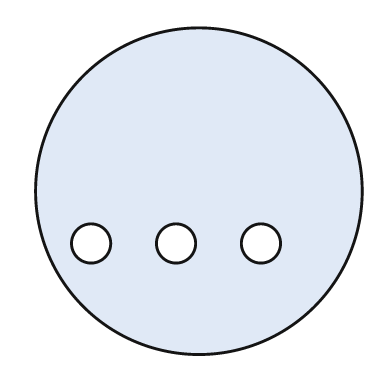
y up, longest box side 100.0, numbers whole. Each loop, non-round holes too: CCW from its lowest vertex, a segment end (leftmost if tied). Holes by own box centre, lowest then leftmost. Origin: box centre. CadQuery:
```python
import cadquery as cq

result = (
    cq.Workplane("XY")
    .moveTo(0.0, 0.0)
    .circle(50.0)
    .moveTo(-33.0, -16.0)
    .circle(6.0)
    .moveTo(-7.0, -16.0)
    .circle(6.0)
    .moveTo(19.0, -16.0)
    .circle(6.0)
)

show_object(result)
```